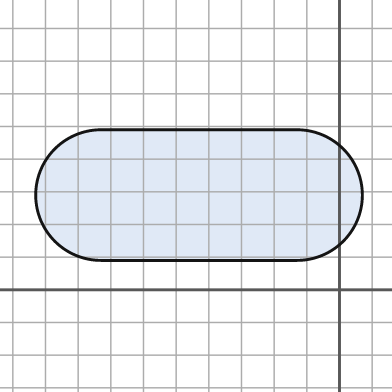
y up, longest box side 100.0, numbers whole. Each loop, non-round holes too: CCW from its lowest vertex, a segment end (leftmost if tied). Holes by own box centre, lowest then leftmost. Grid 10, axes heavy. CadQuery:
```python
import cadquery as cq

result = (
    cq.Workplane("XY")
    .moveTo(-73.0, 9.0)
    .lineTo(-13.0, 9.0)
    .threePointArc((7.0, 29.0), (-13.0, 49.0))
    .lineTo(-73.0, 49.0)
    .threePointArc((-93.0, 29.0), (-73.0, 9.0))
    .close()
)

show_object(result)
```